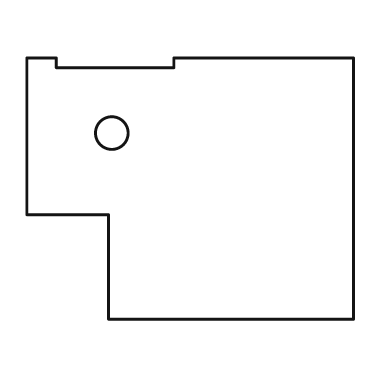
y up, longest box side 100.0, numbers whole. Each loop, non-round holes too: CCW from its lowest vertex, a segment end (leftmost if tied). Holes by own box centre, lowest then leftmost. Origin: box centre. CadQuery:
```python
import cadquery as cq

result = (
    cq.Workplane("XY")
    .moveTo(-25.0, -40.0)
    .lineTo(50.0, -40.0)
    .lineTo(50.0, 40.0)
    .lineTo(-5.0, 40.0)
    .lineTo(-5.0, 37.0)
    .lineTo(-41.0, 37.0)
    .lineTo(-41.0, 40.0)
    .lineTo(-50.0, 40.0)
    .lineTo(-50.0, -8.0)
    .lineTo(-25.0, -8.0)
    .close()
    .moveTo(-24.0, 17.0)
    .circle(5.0)
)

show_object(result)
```